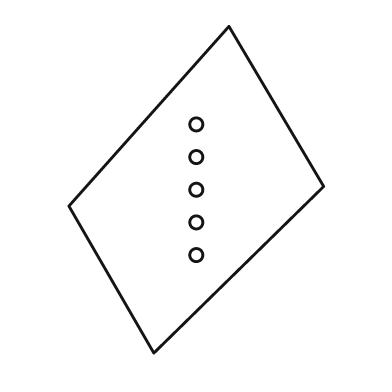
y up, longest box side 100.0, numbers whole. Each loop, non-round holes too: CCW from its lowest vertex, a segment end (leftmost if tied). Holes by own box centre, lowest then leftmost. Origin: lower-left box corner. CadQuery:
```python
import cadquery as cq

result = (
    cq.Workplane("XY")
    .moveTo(26.0, 0.0)
    .lineTo(78.0, 51.0)
    .lineTo(49.0, 100.0)
    .lineTo(0.0, 45.0)
    .close()
    .moveTo(39.0, 30.0)
    .circle(2.0)
    .moveTo(39.0, 40.0)
    .circle(2.0)
    .moveTo(39.0, 50.0)
    .circle(2.0)
    .moveTo(39.0, 60.0)
    .circle(2.0)
    .moveTo(39.0, 70.0)
    .circle(2.0)
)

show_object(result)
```